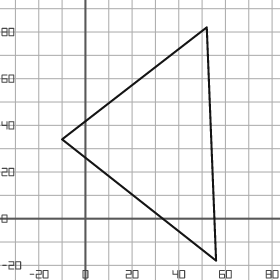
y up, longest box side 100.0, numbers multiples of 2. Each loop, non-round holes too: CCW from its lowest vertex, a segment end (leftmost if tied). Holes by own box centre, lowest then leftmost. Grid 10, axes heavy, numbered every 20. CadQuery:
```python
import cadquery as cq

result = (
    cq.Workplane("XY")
    .moveTo(56.0, -18.0)
    .lineTo(52.0, 82.0)
    .lineTo(-10.0, 34.0)
    .close()
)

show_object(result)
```